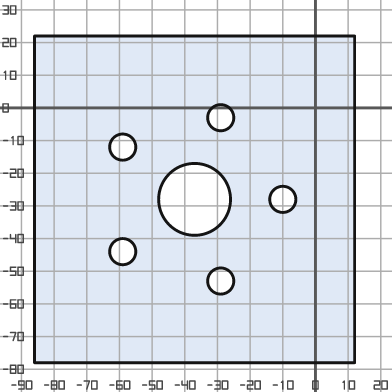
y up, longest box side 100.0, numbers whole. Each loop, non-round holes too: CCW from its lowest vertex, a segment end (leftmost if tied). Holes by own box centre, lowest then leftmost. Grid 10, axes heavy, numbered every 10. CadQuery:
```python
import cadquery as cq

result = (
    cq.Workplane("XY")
    .moveTo(-86.0, -78.0)
    .lineTo(12.0, -78.0)
    .lineTo(12.0, 22.0)
    .lineTo(-86.0, 22.0)
    .close()
    .moveTo(-29.0, -53.0)
    .circle(4.0)
    .moveTo(-59.0, -44.0)
    .circle(4.0)
    .moveTo(-37.0, -28.0)
    .circle(11.0)
    .moveTo(-10.0, -28.0)
    .circle(4.0)
    .moveTo(-59.0, -12.0)
    .circle(4.0)
    .moveTo(-29.0, -3.0)
    .circle(4.0)
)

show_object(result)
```